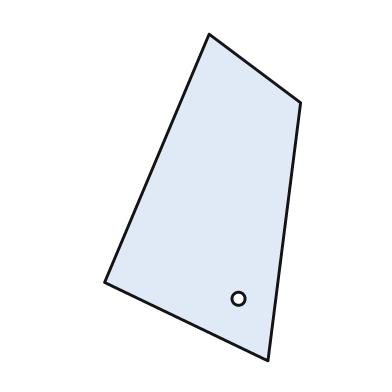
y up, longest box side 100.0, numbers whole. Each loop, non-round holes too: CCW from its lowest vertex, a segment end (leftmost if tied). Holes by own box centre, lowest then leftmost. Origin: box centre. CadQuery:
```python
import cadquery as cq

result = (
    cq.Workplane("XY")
    .moveTo(20.0, -50.0)
    .lineTo(30.0, 29.0)
    .lineTo(2.0, 50.0)
    .lineTo(-30.0, -26.0)
    .close()
    .moveTo(11.0, -31.0)
    .circle(2.0)
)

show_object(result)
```